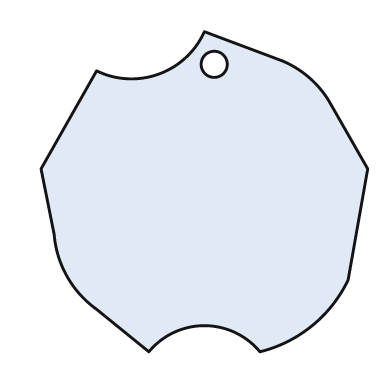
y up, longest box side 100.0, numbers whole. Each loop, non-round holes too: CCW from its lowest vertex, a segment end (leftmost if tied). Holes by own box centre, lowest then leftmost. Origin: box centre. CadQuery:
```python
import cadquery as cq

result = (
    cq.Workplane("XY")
    .moveTo(-17.0, -49.0)
    .threePointArc((0.0, -41.0), (17.0, -49.0))
    .threePointArc((33.0, -41.0), (44.0, -27.0))
    .lineTo(50.0, 7.0)
    .lineTo(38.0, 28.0)
    .threePointArc((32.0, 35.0), (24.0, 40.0))
    .lineTo(0.0, 49.0)
    .threePointArc((-14.0, 36.0), (-33.0, 37.0))
    .lineTo(-50.0, 7.0)
    .lineTo(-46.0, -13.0)
    .threePointArc((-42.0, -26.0), (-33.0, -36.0))
    .close()
    .moveTo(3.0, 39.0)
    .circle(4.0)
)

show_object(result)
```